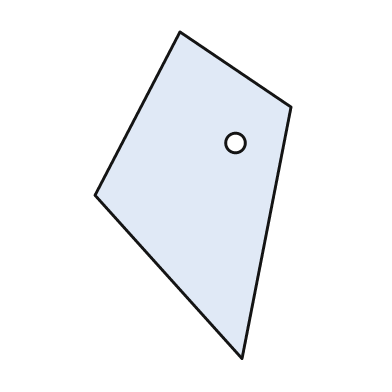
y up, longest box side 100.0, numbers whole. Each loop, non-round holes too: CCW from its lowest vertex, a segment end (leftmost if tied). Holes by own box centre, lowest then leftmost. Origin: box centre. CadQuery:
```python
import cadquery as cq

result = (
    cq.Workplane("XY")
    .moveTo(15.0, -50.0)
    .lineTo(30.0, 27.0)
    .lineTo(-4.0, 50.0)
    .lineTo(-30.0, 0.0)
    .close()
    .moveTo(13.0, 16.0)
    .circle(3.0)
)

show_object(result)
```